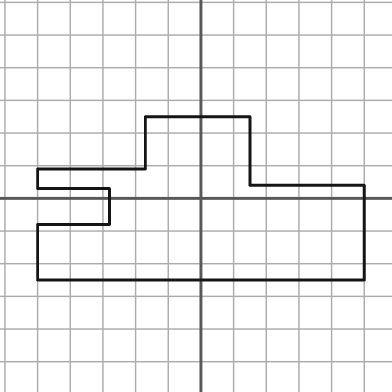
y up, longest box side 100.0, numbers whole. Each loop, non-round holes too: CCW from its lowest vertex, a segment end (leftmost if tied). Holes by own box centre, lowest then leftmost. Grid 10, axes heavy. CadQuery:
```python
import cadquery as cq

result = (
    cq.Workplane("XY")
    .moveTo(-50.0, -25.0)
    .lineTo(50.0, -25.0)
    .lineTo(50.0, 4.0)
    .lineTo(15.0, 4.0)
    .lineTo(15.0, 25.0)
    .lineTo(-17.0, 25.0)
    .lineTo(-17.0, 9.0)
    .lineTo(-50.0, 9.0)
    .lineTo(-50.0, 3.0)
    .lineTo(-28.0, 3.0)
    .lineTo(-28.0, -8.0)
    .lineTo(-50.0, -8.0)
    .close()
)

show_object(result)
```